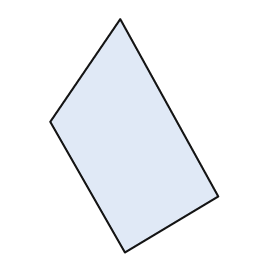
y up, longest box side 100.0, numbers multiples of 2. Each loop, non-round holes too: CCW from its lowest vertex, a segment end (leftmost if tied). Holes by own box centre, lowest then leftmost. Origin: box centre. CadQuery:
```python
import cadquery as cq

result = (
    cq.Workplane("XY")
    .moveTo(-4.0, -50.0)
    .lineTo(36.0, -26.0)
    .lineTo(-6.0, 50.0)
    .lineTo(-36.0, 6.0)
    .close()
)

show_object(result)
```